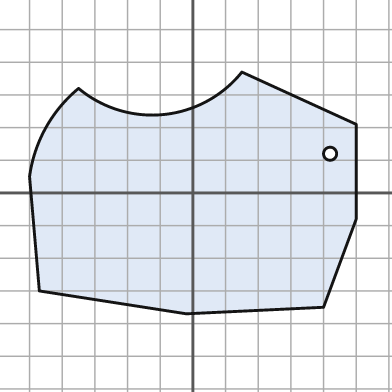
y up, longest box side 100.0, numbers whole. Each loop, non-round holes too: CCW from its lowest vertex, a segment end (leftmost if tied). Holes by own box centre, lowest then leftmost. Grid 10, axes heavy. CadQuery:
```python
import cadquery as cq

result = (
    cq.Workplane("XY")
    .moveTo(-2.0, -37.0)
    .lineTo(40.0, -35.0)
    .lineTo(50.0, -8.0)
    .lineTo(50.0, 21.0)
    .lineTo(15.0, 37.0)
    .threePointArc((-9.0, 24.0), (-35.0, 32.0))
    .threePointArc((-45.0, 20.0), (-50.0, 5.0))
    .lineTo(-47.0, -30.0)
    .close()
    .moveTo(42.0, 12.0)
    .circle(2.0)
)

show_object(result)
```